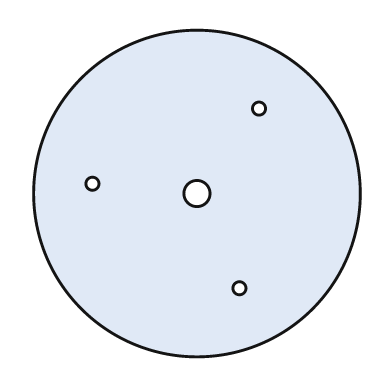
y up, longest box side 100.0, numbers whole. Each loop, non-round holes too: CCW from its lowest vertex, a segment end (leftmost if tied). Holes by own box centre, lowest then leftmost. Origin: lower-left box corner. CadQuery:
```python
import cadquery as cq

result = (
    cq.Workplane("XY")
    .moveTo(50.0, 50.0)
    .circle(50.0)
    .moveTo(63.0, 21.0)
    .circle(2.0)
    .moveTo(50.0, 50.0)
    .circle(4.0)
    .moveTo(18.0, 53.0)
    .circle(2.0)
    .moveTo(69.0, 76.0)
    .circle(2.0)
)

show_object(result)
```